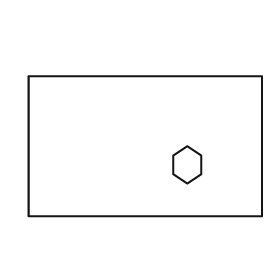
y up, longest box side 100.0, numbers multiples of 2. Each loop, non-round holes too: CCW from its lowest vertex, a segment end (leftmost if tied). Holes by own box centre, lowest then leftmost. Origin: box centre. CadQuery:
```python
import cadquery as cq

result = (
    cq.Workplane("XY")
    .moveTo(-50.0, -30.0)
    .lineTo(50.0, -30.0)
    .lineTo(50.0, 30.0)
    .lineTo(-50.0, 30.0)
    .close()
    .moveTo(18.0, -16.0)
    .lineTo(24.0, -12.0)
    .lineTo(24.0, -4.0)
    .lineTo(18.0, 0.0)
    .lineTo(12.0, -4.0)
    .lineTo(12.0, -12.0)
    .close()
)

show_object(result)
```